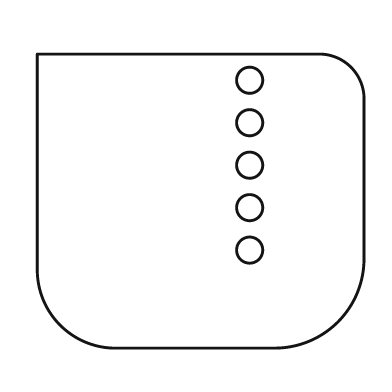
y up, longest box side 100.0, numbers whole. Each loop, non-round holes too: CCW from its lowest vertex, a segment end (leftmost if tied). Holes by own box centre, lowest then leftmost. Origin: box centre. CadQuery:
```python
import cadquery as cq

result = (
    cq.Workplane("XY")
    .moveTo(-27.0, -45.0)
    .lineTo(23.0, -45.0)
    .threePointArc((42.0, -37.0), (50.0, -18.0))
    .lineTo(50.0, 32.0)
    .threePointArc((46.0, 41.0), (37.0, 45.0))
    .lineTo(-50.0, 45.0)
    .lineTo(-50.0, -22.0)
    .threePointArc((-43.0, -38.0), (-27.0, -45.0))
    .close()
    .moveTo(15.0, -15.0)
    .circle(4.0)
    .moveTo(15.0, -2.0)
    .circle(4.0)
    .moveTo(15.0, 11.0)
    .circle(4.0)
    .moveTo(15.0, 24.0)
    .circle(4.0)
    .moveTo(15.0, 37.0)
    .circle(4.0)
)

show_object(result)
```